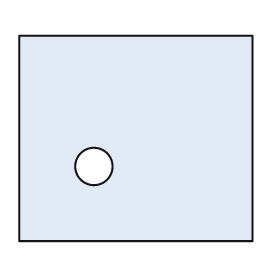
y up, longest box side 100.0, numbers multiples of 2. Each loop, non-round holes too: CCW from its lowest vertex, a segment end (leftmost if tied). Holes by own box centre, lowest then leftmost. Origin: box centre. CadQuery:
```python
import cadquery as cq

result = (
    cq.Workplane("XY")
    .moveTo(-50.0, -44.0)
    .lineTo(50.0, -44.0)
    .lineTo(50.0, 44.0)
    .lineTo(-50.0, 44.0)
    .close()
    .moveTo(-18.0, -12.0)
    .circle(8.0)
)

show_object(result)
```